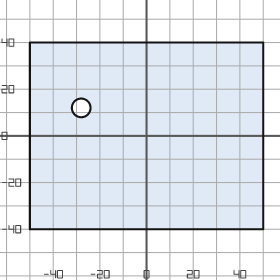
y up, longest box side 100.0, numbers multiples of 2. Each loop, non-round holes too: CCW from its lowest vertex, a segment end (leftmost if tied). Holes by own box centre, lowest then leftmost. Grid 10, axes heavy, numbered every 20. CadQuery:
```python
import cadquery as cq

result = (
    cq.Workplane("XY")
    .moveTo(-50.0, -40.0)
    .lineTo(50.0, -40.0)
    .lineTo(50.0, 40.0)
    .lineTo(-50.0, 40.0)
    .close()
    .moveTo(-28.0, 12.0)
    .circle(4.0)
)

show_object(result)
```